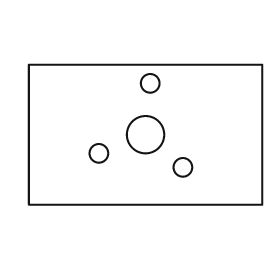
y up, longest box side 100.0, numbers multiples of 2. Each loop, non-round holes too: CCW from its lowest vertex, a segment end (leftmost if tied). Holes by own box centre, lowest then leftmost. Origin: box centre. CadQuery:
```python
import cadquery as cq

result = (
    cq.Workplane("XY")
    .moveTo(-50.0, -30.0)
    .lineTo(50.0, -30.0)
    .lineTo(50.0, 30.0)
    .lineTo(-50.0, 30.0)
    .close()
    .moveTo(16.0, -14.0)
    .circle(4.0)
    .moveTo(-20.0, -8.0)
    .circle(4.0)
    .moveTo(0.0, 0.0)
    .circle(8.0)
    .moveTo(2.0, 22.0)
    .circle(4.0)
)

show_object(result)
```